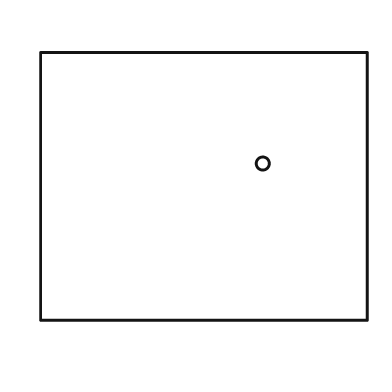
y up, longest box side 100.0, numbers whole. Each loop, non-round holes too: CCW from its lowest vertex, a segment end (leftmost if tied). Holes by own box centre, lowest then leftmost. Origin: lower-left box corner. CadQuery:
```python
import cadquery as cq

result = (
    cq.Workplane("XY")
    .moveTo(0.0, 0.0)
    .lineTo(100.0, 0.0)
    .lineTo(100.0, 82.0)
    .lineTo(0.0, 82.0)
    .close()
    .moveTo(68.0, 48.0)
    .circle(2.0)
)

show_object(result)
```